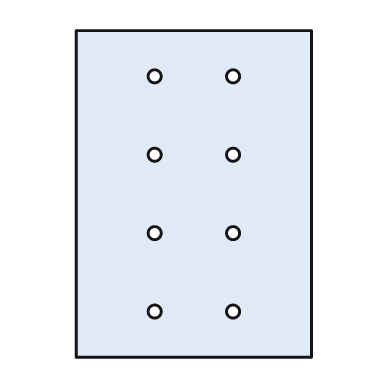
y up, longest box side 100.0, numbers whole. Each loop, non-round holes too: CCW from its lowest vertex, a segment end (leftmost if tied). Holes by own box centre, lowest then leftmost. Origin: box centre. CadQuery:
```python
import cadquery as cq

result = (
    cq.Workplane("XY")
    .moveTo(-36.0, -50.0)
    .lineTo(36.0, -50.0)
    .lineTo(36.0, 50.0)
    .lineTo(-36.0, 50.0)
    .close()
    .moveTo(-12.0, -36.0)
    .circle(2.0)
    .moveTo(12.0, -36.0)
    .circle(2.0)
    .moveTo(-12.0, -12.0)
    .circle(2.0)
    .moveTo(12.0, -12.0)
    .circle(2.0)
    .moveTo(-12.0, 12.0)
    .circle(2.0)
    .moveTo(12.0, 12.0)
    .circle(2.0)
    .moveTo(-12.0, 36.0)
    .circle(2.0)
    .moveTo(12.0, 36.0)
    .circle(2.0)
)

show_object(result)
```